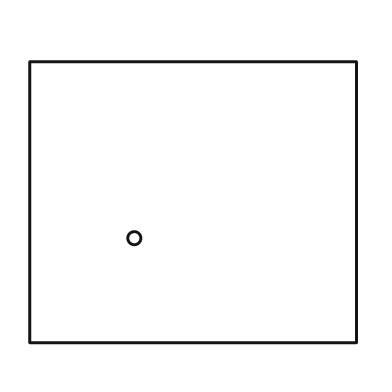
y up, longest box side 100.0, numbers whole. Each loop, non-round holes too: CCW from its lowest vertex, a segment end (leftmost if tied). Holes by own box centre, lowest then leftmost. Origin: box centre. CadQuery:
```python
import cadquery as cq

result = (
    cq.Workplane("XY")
    .moveTo(-50.0, -43.0)
    .lineTo(50.0, -43.0)
    .lineTo(50.0, 43.0)
    .lineTo(-50.0, 43.0)
    .close()
    .moveTo(-18.0, -11.0)
    .circle(2.0)
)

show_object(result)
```